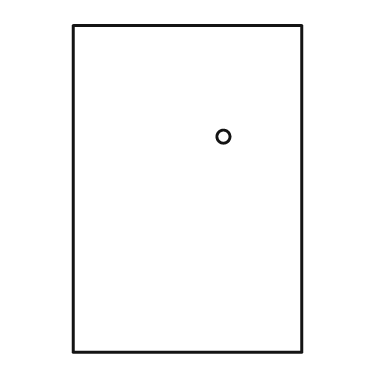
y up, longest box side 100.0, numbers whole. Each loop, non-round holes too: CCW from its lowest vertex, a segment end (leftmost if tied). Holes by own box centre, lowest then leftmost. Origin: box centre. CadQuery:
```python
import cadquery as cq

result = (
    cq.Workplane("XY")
    .moveTo(-35.0, -50.0)
    .lineTo(35.0, -50.0)
    .lineTo(35.0, 50.0)
    .lineTo(-35.0, 50.0)
    .close()
    .moveTo(11.0, 16.0)
    .circle(2.0)
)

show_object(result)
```